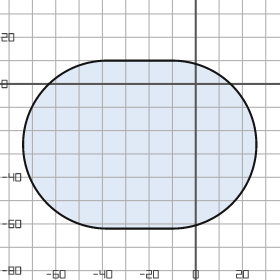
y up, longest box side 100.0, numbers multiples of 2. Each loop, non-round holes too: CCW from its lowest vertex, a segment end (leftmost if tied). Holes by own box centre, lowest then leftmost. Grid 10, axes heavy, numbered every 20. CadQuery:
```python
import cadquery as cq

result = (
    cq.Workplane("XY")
    .moveTo(-38.0, -62.0)
    .lineTo(-10.0, -62.0)
    .threePointArc((26.0, -26.0), (-10.0, 10.0))
    .lineTo(-38.0, 10.0)
    .threePointArc((-74.0, -26.0), (-38.0, -62.0))
    .close()
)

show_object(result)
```